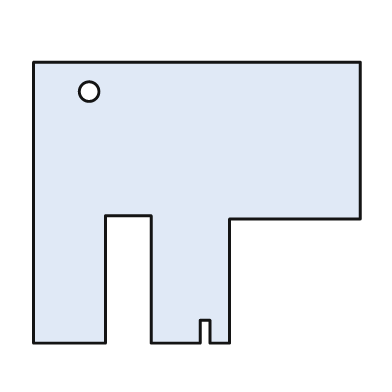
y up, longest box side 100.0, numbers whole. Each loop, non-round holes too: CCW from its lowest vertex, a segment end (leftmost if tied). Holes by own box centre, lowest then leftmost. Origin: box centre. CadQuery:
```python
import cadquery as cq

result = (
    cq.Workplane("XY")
    .moveTo(-50.0, -43.0)
    .lineTo(-28.0, -43.0)
    .lineTo(-28.0, -4.0)
    .lineTo(-14.0, -4.0)
    .lineTo(-14.0, -43.0)
    .lineTo(1.0, -43.0)
    .lineTo(1.0, -36.0)
    .lineTo(4.0, -36.0)
    .lineTo(4.0, -43.0)
    .lineTo(10.0, -43.0)
    .lineTo(10.0, -5.0)
    .lineTo(50.0, -5.0)
    .lineTo(50.0, 43.0)
    .lineTo(-50.0, 43.0)
    .close()
    .moveTo(-33.0, 34.0)
    .circle(3.0)
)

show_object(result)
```